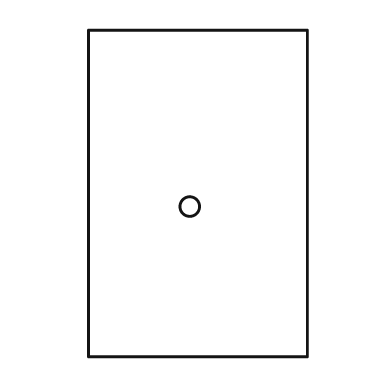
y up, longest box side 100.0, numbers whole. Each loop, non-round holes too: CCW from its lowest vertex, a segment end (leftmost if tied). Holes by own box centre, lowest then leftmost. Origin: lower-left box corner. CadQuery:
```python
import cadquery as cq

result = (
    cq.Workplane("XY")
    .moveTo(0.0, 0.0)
    .lineTo(67.0, 0.0)
    .lineTo(67.0, 100.0)
    .lineTo(0.0, 100.0)
    .close()
    .moveTo(31.0, 46.0)
    .circle(3.0)
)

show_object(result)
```